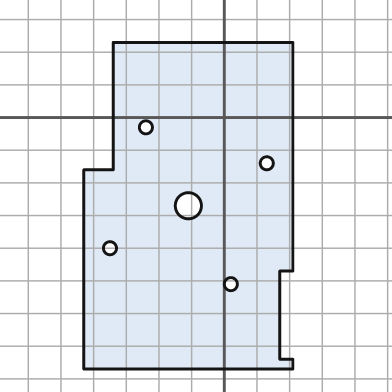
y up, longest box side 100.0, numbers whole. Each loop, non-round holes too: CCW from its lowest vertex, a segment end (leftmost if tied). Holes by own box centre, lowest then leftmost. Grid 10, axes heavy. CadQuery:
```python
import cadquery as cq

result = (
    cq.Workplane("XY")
    .moveTo(-43.0, -77.0)
    .lineTo(21.0, -77.0)
    .lineTo(21.0, -74.0)
    .lineTo(17.0, -74.0)
    .lineTo(17.0, -47.0)
    .lineTo(21.0, -47.0)
    .lineTo(21.0, 23.0)
    .lineTo(-34.0, 23.0)
    .lineTo(-34.0, -16.0)
    .lineTo(-43.0, -16.0)
    .close()
    .moveTo(2.0, -51.0)
    .circle(2.0)
    .moveTo(-35.0, -40.0)
    .circle(2.0)
    .moveTo(-11.0, -27.0)
    .circle(4.0)
    .moveTo(13.0, -14.0)
    .circle(2.0)
    .moveTo(-24.0, -3.0)
    .circle(2.0)
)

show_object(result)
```